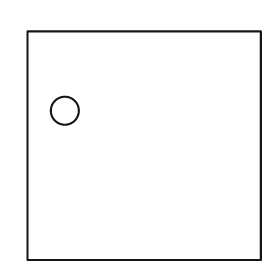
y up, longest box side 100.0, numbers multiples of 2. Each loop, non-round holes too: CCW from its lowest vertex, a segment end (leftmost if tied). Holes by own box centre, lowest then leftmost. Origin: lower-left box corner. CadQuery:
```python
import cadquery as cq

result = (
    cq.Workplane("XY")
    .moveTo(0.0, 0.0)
    .lineTo(100.0, 0.0)
    .lineTo(100.0, 98.0)
    .lineTo(0.0, 98.0)
    .close()
    .moveTo(16.0, 64.0)
    .circle(6.0)
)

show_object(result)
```